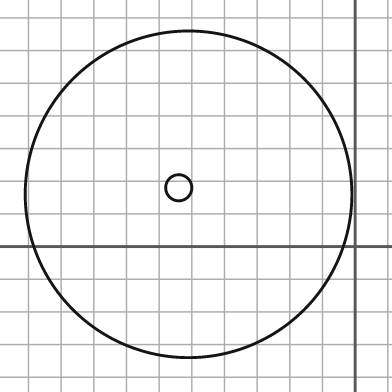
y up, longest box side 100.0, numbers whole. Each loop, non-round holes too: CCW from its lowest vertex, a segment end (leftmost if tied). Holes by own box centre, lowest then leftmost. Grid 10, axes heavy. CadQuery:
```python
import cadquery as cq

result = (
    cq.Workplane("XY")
    .moveTo(-51.0, 16.0)
    .circle(50.0)
    .moveTo(-54.0, 18.0)
    .circle(4.0)
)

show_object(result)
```